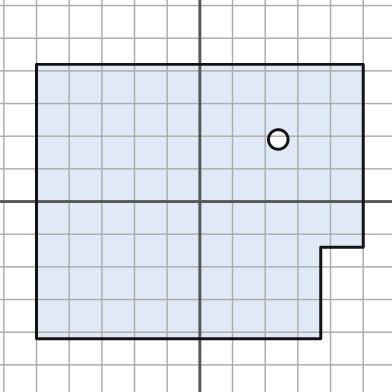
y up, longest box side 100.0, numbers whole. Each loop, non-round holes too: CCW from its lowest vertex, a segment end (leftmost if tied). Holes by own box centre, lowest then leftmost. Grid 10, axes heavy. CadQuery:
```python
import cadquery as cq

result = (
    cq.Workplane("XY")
    .moveTo(-50.0, -42.0)
    .lineTo(37.0, -42.0)
    .lineTo(37.0, -14.0)
    .lineTo(50.0, -14.0)
    .lineTo(50.0, 42.0)
    .lineTo(-50.0, 42.0)
    .close()
    .moveTo(24.0, 19.0)
    .circle(3.0)
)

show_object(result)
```